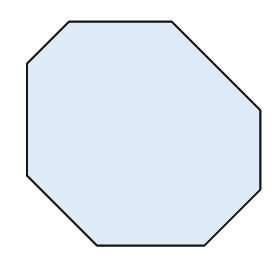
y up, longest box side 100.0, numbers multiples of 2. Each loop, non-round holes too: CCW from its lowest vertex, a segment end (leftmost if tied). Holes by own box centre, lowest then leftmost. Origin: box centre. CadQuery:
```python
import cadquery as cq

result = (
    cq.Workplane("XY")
    .moveTo(-20.0, -48.0)
    .lineTo(26.0, -48.0)
    .lineTo(50.0, -24.0)
    .lineTo(50.0, 10.0)
    .lineTo(12.0, 48.0)
    .lineTo(-32.0, 48.0)
    .lineTo(-50.0, 30.0)
    .lineTo(-50.0, -18.0)
    .close()
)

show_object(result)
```